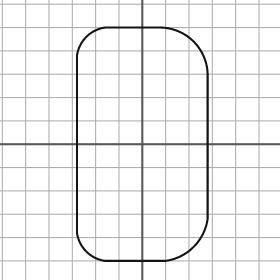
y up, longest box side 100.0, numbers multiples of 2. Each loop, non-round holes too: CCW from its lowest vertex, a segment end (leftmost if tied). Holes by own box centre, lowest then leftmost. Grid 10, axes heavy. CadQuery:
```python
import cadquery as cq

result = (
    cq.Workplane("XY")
    .moveTo(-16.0, -50.0)
    .lineTo(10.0, -50.0)
    .threePointArc((22.0, -44.0), (28.0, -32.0))
    .lineTo(28.0, 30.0)
    .threePointArc((22.0, 44.0), (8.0, 50.0))
    .lineTo(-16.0, 50.0)
    .threePointArc((-24.0, 46.0), (-28.0, 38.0))
    .lineTo(-28.0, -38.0)
    .threePointArc((-24.0, -46.0), (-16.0, -50.0))
    .close()
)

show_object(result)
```